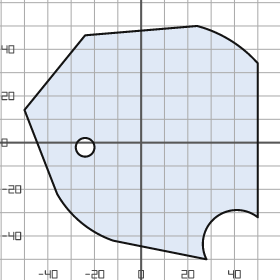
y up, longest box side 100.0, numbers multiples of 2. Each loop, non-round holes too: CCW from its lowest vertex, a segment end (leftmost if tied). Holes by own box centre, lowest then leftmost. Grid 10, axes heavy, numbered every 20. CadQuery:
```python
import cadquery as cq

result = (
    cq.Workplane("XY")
    .moveTo(28.0, -50.0)
    .threePointArc((32.0, -32.0), (50.0, -32.0))
    .lineTo(50.0, 34.0)
    .threePointArc((38.0, 44.0), (24.0, 50.0))
    .lineTo(-24.0, 46.0)
    .lineTo(-50.0, 14.0)
    .lineTo(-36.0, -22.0)
    .threePointArc((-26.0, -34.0), (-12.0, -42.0))
    .close()
    .moveTo(-24.0, -2.0)
    .circle(4.0)
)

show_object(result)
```